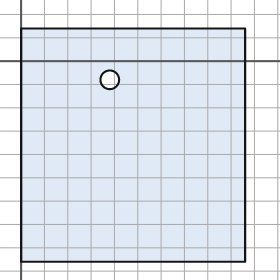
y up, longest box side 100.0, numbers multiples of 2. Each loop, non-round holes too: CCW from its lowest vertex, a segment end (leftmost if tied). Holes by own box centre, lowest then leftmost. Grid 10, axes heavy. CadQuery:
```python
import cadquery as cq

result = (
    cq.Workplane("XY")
    .moveTo(0.0, -86.0)
    .lineTo(96.0, -86.0)
    .lineTo(96.0, 14.0)
    .lineTo(0.0, 14.0)
    .close()
    .moveTo(38.0, -8.0)
    .circle(4.0)
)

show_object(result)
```